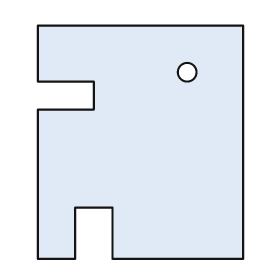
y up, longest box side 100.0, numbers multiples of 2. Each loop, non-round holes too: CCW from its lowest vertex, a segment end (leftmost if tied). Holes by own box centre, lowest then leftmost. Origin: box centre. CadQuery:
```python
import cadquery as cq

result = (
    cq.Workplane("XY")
    .moveTo(-44.0, -50.0)
    .lineTo(-28.0, -50.0)
    .lineTo(-28.0, -28.0)
    .lineTo(-12.0, -28.0)
    .lineTo(-12.0, -50.0)
    .lineTo(44.0, -50.0)
    .lineTo(44.0, 50.0)
    .lineTo(-44.0, 50.0)
    .lineTo(-44.0, 26.0)
    .lineTo(-20.0, 26.0)
    .lineTo(-20.0, 14.0)
    .lineTo(-44.0, 14.0)
    .close()
    .moveTo(20.0, 30.0)
    .circle(4.0)
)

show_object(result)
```